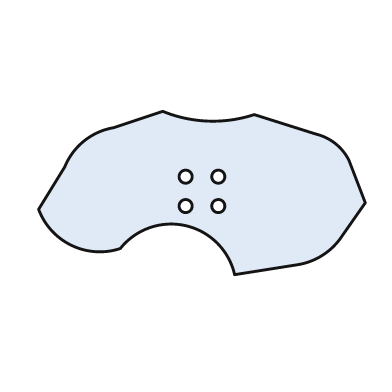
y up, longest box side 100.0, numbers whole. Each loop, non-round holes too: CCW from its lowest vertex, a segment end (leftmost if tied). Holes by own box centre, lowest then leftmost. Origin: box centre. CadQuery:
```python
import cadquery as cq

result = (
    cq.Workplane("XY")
    .moveTo(10.0, -25.0)
    .lineTo(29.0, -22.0)
    .threePointArc((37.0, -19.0), (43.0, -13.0))
    .lineTo(50.0, -3.0)
    .lineTo(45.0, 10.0)
    .threePointArc((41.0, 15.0), (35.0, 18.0))
    .lineTo(16.0, 24.0)
    .threePointArc((2.0, 22.0), (-12.0, 25.0))
    .lineTo(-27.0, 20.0)
    .threePointArc((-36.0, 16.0), (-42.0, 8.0))
    .lineTo(-50.0, -5.0)
    .threePointArc((-40.0, -16.0), (-25.0, -17.0))
    .threePointArc((-5.0, -10.0), (10.0, -25.0))
    .close()
    .moveTo(-5.0, -4.0)
    .circle(2.0)
    .moveTo(5.0, -4.0)
    .circle(2.0)
    .moveTo(-5.0, 5.0)
    .circle(2.0)
    .moveTo(5.0, 5.0)
    .circle(2.0)
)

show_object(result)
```